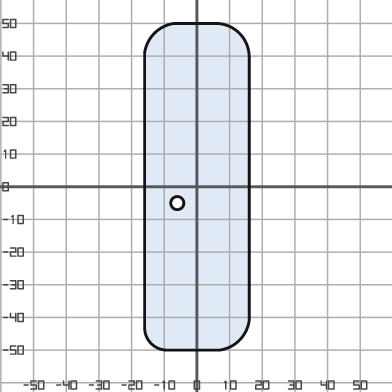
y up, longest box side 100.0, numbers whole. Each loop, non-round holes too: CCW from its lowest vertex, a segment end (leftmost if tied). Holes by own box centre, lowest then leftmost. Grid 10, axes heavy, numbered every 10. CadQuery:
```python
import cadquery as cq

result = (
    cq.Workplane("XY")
    .moveTo(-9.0, -50.0)
    .lineTo(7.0, -50.0)
    .threePointArc((13.0, -47.0), (16.0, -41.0))
    .lineTo(16.0, 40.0)
    .threePointArc((13.0, 47.0), (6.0, 50.0))
    .lineTo(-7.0, 50.0)
    .threePointArc((-13.0, 47.0), (-16.0, 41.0))
    .lineTo(-16.0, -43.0)
    .threePointArc((-14.0, -48.0), (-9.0, -50.0))
    .close()
    .moveTo(-6.0, -5.0)
    .circle(2.0)
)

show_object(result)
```